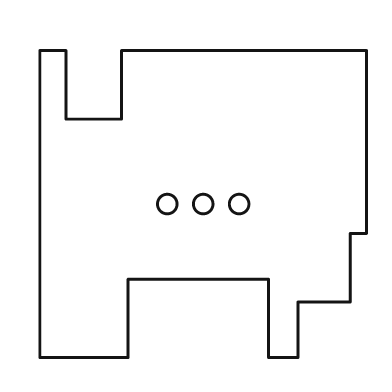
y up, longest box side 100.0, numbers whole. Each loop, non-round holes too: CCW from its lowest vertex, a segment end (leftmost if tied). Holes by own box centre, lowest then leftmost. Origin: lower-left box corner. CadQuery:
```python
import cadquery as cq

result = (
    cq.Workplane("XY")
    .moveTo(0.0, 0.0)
    .lineTo(27.0, 0.0)
    .lineTo(27.0, 24.0)
    .lineTo(70.0, 24.0)
    .lineTo(70.0, 0.0)
    .lineTo(79.0, 0.0)
    .lineTo(79.0, 17.0)
    .lineTo(95.0, 17.0)
    .lineTo(95.0, 38.0)
    .lineTo(100.0, 38.0)
    .lineTo(100.0, 94.0)
    .lineTo(25.0, 94.0)
    .lineTo(25.0, 73.0)
    .lineTo(8.0, 73.0)
    .lineTo(8.0, 94.0)
    .lineTo(0.0, 94.0)
    .close()
    .moveTo(39.0, 47.0)
    .circle(3.0)
    .moveTo(50.0, 47.0)
    .circle(3.0)
    .moveTo(61.0, 47.0)
    .circle(3.0)
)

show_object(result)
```